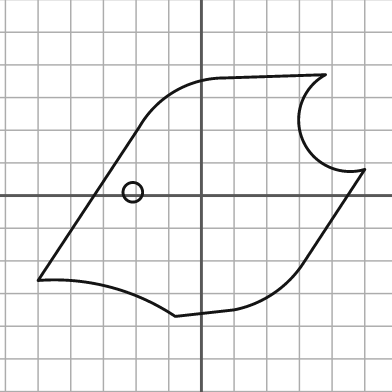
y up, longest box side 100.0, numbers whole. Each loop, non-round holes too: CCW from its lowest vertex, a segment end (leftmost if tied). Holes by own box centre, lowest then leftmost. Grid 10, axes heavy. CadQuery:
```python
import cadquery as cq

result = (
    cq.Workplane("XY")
    .moveTo(-8.0, -37.0)
    .lineTo(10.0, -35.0)
    .threePointArc((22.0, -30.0), (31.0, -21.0))
    .lineTo(50.0, 8.0)
    .threePointArc((31.0, 17.0), (38.0, 37.0))
    .lineTo(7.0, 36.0)
    .threePointArc((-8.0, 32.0), (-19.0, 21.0))
    .lineTo(-50.0, -26.0)
    .threePointArc((-28.0, -28.0), (-8.0, -37.0))
    .close()
    .moveTo(-21.0, 1.0)
    .circle(3.0)
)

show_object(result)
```